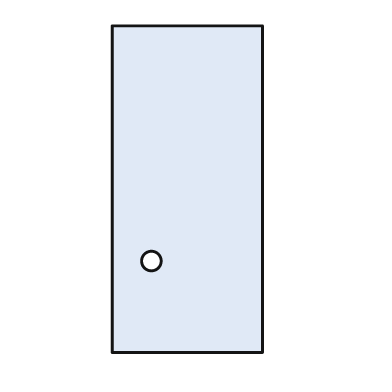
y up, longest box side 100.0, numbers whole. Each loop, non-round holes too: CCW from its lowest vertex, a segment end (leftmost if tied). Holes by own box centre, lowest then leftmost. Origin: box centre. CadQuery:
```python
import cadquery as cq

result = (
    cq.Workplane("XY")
    .moveTo(-23.0, -50.0)
    .lineTo(23.0, -50.0)
    .lineTo(23.0, 50.0)
    .lineTo(-23.0, 50.0)
    .close()
    .moveTo(-11.0, -22.0)
    .circle(3.0)
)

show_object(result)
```